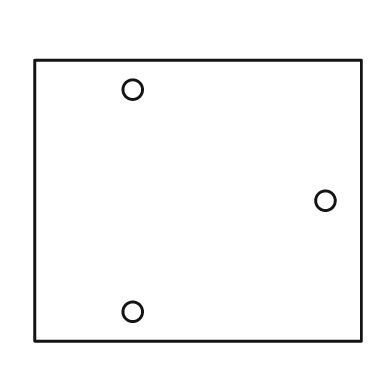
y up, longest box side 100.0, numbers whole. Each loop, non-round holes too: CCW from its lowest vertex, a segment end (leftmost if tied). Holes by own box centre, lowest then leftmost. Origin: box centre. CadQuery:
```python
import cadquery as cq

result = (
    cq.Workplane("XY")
    .moveTo(-50.0, -43.0)
    .lineTo(50.0, -43.0)
    .lineTo(50.0, 43.0)
    .lineTo(-50.0, 43.0)
    .close()
    .moveTo(-20.0, -34.0)
    .circle(3.0)
    .moveTo(39.0, 0.0)
    .circle(3.0)
    .moveTo(-20.0, 34.0)
    .circle(3.0)
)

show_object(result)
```